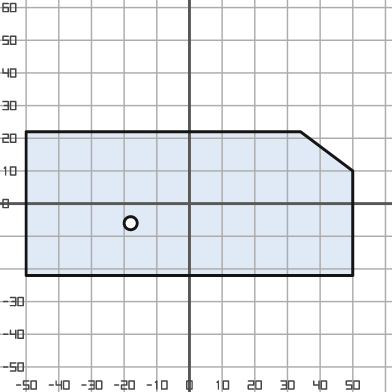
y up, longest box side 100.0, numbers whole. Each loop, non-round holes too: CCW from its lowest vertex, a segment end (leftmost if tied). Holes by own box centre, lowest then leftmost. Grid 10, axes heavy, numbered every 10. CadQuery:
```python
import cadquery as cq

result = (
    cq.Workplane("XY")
    .moveTo(-50.0, -22.0)
    .lineTo(50.0, -22.0)
    .lineTo(50.0, 10.0)
    .lineTo(34.0, 22.0)
    .lineTo(-50.0, 22.0)
    .close()
    .moveTo(-18.0, -6.0)
    .circle(2.0)
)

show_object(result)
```